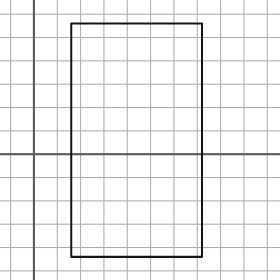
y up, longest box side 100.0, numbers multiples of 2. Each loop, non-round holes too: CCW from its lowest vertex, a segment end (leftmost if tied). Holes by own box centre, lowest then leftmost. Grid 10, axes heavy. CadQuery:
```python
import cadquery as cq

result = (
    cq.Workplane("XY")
    .moveTo(16.0, -44.0)
    .lineTo(72.0, -44.0)
    .lineTo(72.0, 56.0)
    .lineTo(16.0, 56.0)
    .close()
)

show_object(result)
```